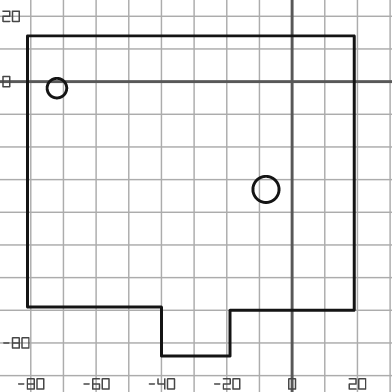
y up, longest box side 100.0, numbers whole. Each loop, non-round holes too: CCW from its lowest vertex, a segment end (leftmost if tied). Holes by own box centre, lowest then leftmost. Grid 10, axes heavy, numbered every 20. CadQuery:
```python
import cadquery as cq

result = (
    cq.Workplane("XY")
    .moveTo(-40.0, -84.0)
    .lineTo(-19.0, -84.0)
    .lineTo(-19.0, -70.0)
    .lineTo(19.0, -70.0)
    .lineTo(19.0, 14.0)
    .lineTo(-81.0, 14.0)
    .lineTo(-81.0, -69.0)
    .lineTo(-40.0, -69.0)
    .close()
    .moveTo(-8.0, -33.0)
    .circle(4.0)
    .moveTo(-72.0, -2.0)
    .circle(3.0)
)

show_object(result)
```